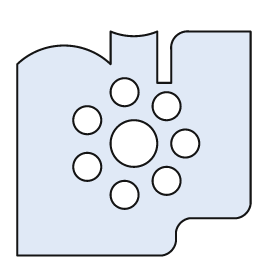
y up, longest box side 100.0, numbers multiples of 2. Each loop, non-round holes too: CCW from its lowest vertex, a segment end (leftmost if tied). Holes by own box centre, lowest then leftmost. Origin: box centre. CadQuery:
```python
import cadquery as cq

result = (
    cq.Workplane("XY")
    .moveTo(-50.0, -48.0)
    .lineTo(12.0, -48.0)
    .threePointArc((16.0, -46.0), (18.0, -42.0))
    .lineTo(18.0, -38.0)
    .threePointArc((20.0, -34.0), (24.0, -32.0))
    .lineTo(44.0, -32.0)
    .threePointArc((48.0, -30.0), (50.0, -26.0))
    .lineTo(50.0, 48.0)
    .lineTo(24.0, 48.0)
    .threePointArc((18.0, 46.0), (16.0, 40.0))
    .lineTo(16.0, 26.0)
    .lineTo(10.0, 26.0)
    .lineTo(10.0, 48.0)
    .threePointArc((0.0, 46.0), (-10.0, 48.0))
    .lineTo(-10.0, 34.0)
    .threePointArc((-30.0, 42.0), (-50.0, 34.0))
    .close()
    .moveTo(-4.0, -22.0)
    .circle(6.0)
    .moveTo(14.0, -16.0)
    .circle(6.0)
    .moveTo(-20.0, -10.0)
    .circle(6.0)
    .moveTo(0.0, 0.0)
    .circle(10.0)
    .moveTo(22.0, 0.0)
    .circle(6.0)
    .moveTo(-20.0, 10.0)
    .circle(6.0)
    .moveTo(14.0, 16.0)
    .circle(6.0)
    .moveTo(-4.0, 22.0)
    .circle(6.0)
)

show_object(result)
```